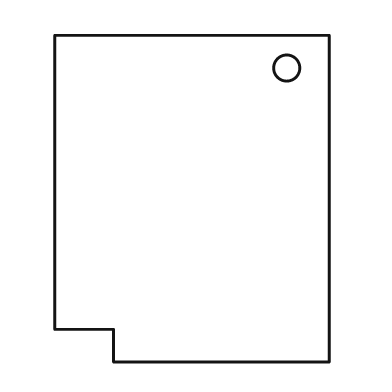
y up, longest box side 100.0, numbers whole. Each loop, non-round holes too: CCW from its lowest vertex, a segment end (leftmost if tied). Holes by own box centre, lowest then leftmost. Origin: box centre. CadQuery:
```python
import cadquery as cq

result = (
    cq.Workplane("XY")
    .moveTo(-24.0, -50.0)
    .lineTo(42.0, -50.0)
    .lineTo(42.0, 50.0)
    .lineTo(-42.0, 50.0)
    .lineTo(-42.0, -40.0)
    .lineTo(-24.0, -40.0)
    .close()
    .moveTo(29.0, 40.0)
    .circle(4.0)
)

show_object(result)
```